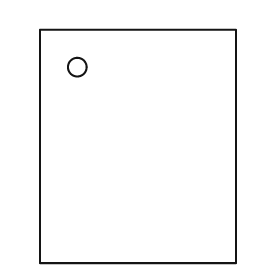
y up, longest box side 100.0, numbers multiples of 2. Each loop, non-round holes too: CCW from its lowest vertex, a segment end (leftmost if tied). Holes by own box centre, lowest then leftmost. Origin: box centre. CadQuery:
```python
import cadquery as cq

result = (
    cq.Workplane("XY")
    .moveTo(-42.0, -50.0)
    .lineTo(42.0, -50.0)
    .lineTo(42.0, 50.0)
    .lineTo(-42.0, 50.0)
    .close()
    .moveTo(-26.0, 34.0)
    .circle(4.0)
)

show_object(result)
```